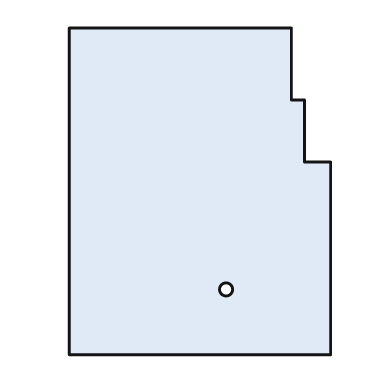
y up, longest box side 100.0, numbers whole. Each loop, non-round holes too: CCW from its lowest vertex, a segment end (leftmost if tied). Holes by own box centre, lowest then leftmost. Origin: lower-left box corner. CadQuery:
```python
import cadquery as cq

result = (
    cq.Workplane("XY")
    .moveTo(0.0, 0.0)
    .lineTo(80.0, 0.0)
    .lineTo(80.0, 59.0)
    .lineTo(72.0, 59.0)
    .lineTo(72.0, 78.0)
    .lineTo(68.0, 78.0)
    .lineTo(68.0, 100.0)
    .lineTo(0.0, 100.0)
    .close()
    .moveTo(48.0, 20.0)
    .circle(2.0)
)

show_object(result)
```